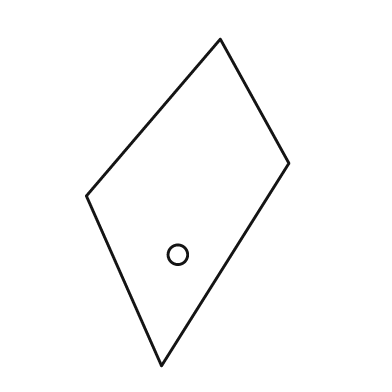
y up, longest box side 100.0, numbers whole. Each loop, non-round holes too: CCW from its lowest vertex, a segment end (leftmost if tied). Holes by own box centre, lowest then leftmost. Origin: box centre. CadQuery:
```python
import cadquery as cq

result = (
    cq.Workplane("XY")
    .moveTo(-8.0, -50.0)
    .lineTo(31.0, 12.0)
    .lineTo(10.0, 50.0)
    .lineTo(-31.0, 2.0)
    .close()
    .moveTo(-3.0, -16.0)
    .circle(3.0)
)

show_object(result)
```